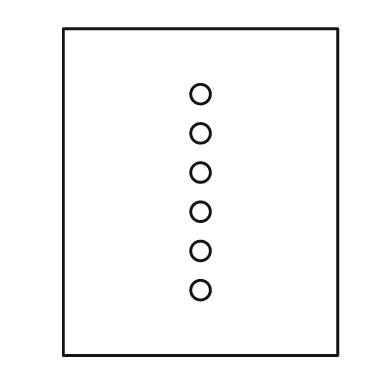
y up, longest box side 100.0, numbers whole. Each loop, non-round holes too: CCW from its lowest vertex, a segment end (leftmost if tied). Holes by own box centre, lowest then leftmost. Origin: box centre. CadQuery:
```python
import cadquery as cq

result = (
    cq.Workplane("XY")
    .moveTo(-42.0, -50.0)
    .lineTo(42.0, -50.0)
    .lineTo(42.0, 50.0)
    .lineTo(-42.0, 50.0)
    .close()
    .moveTo(0.0, -30.0)
    .circle(3.0)
    .moveTo(0.0, -18.0)
    .circle(3.0)
    .moveTo(0.0, -6.0)
    .circle(3.0)
    .moveTo(0.0, 6.0)
    .circle(3.0)
    .moveTo(0.0, 18.0)
    .circle(3.0)
    .moveTo(0.0, 30.0)
    .circle(3.0)
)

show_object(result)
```